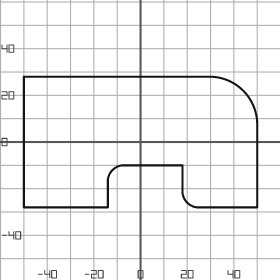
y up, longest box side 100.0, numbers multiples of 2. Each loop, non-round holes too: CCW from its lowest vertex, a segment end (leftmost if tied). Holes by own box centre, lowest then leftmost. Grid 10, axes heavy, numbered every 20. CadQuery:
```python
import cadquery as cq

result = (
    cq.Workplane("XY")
    .moveTo(-50.0, -28.0)
    .lineTo(-14.0, -28.0)
    .lineTo(-14.0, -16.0)
    .threePointArc((-12.0, -12.0), (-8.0, -10.0))
    .lineTo(18.0, -10.0)
    .lineTo(18.0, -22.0)
    .threePointArc((20.0, -26.0), (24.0, -28.0))
    .lineTo(50.0, -28.0)
    .lineTo(50.0, 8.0)
    .threePointArc((44.0, 22.0), (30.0, 28.0))
    .lineTo(-50.0, 28.0)
    .close()
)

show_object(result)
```